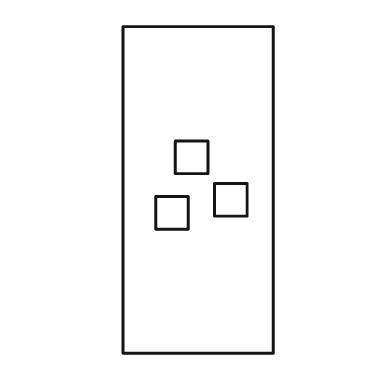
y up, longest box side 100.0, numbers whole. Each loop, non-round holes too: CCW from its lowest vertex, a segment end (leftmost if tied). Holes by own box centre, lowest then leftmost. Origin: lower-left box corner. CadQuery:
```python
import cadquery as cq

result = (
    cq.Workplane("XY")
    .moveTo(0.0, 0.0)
    .lineTo(46.0, 0.0)
    .lineTo(46.0, 100.0)
    .lineTo(0.0, 100.0)
    .close()
    .moveTo(10.0, 38.0)
    .lineTo(20.0, 38.0)
    .lineTo(20.0, 48.0)
    .lineTo(10.0, 48.0)
    .close()
    .moveTo(28.0, 42.0)
    .lineTo(38.0, 42.0)
    .lineTo(38.0, 52.0)
    .lineTo(28.0, 52.0)
    .close()
    .moveTo(16.0, 55.0)
    .lineTo(26.0, 55.0)
    .lineTo(26.0, 65.0)
    .lineTo(16.0, 65.0)
    .close()
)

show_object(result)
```